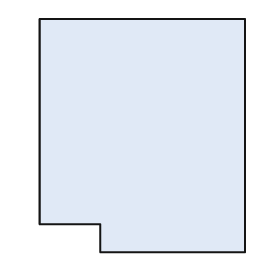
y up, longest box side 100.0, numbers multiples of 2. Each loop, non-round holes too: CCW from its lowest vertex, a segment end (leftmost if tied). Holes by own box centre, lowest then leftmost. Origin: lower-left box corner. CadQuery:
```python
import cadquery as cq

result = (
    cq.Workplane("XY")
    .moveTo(26.0, 0.0)
    .lineTo(88.0, 0.0)
    .lineTo(88.0, 100.0)
    .lineTo(0.0, 100.0)
    .lineTo(0.0, 12.0)
    .lineTo(26.0, 12.0)
    .close()
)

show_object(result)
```